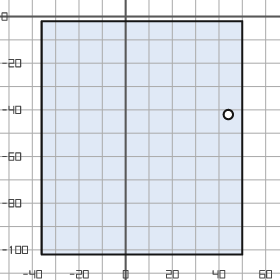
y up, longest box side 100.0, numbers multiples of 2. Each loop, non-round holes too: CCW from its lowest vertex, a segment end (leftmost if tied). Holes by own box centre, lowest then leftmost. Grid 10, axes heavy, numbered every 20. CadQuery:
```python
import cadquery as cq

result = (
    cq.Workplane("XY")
    .moveTo(-36.0, -102.0)
    .lineTo(50.0, -102.0)
    .lineTo(50.0, -2.0)
    .lineTo(-36.0, -2.0)
    .close()
    .moveTo(44.0, -42.0)
    .circle(2.0)
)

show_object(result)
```